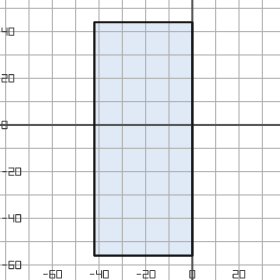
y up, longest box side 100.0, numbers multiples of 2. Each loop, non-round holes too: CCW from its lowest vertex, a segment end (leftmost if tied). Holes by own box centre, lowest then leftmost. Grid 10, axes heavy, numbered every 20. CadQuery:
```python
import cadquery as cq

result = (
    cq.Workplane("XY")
    .moveTo(-42.0, -56.0)
    .lineTo(0.0, -56.0)
    .lineTo(0.0, 44.0)
    .lineTo(-42.0, 44.0)
    .close()
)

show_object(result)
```